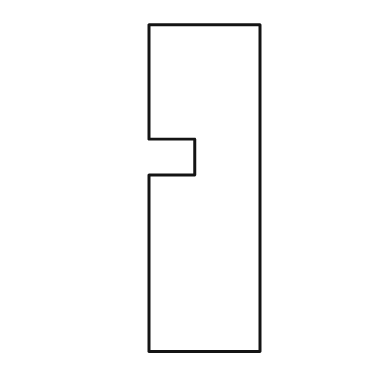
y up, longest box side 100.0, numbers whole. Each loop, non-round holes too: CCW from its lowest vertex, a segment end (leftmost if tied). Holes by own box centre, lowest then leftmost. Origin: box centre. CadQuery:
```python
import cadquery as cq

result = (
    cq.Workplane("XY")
    .moveTo(-17.0, -50.0)
    .lineTo(17.0, -50.0)
    .lineTo(17.0, 50.0)
    .lineTo(-17.0, 50.0)
    .lineTo(-17.0, 15.0)
    .lineTo(-3.0, 15.0)
    .lineTo(-3.0, 4.0)
    .lineTo(-17.0, 4.0)
    .close()
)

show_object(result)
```